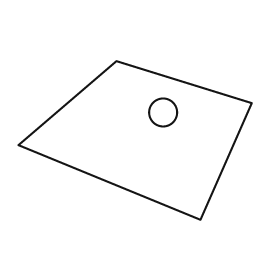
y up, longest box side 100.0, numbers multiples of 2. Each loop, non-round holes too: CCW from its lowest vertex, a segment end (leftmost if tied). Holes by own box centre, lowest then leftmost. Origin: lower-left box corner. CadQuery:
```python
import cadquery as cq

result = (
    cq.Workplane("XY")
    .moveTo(78.0, 0.0)
    .lineTo(100.0, 50.0)
    .lineTo(42.0, 68.0)
    .lineTo(0.0, 32.0)
    .close()
    .moveTo(62.0, 46.0)
    .circle(6.0)
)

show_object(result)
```